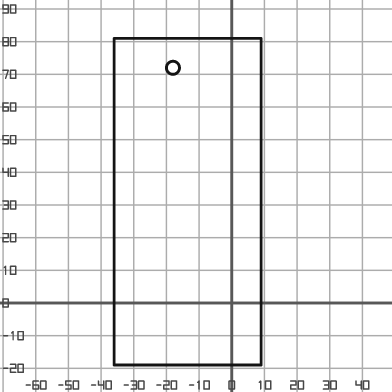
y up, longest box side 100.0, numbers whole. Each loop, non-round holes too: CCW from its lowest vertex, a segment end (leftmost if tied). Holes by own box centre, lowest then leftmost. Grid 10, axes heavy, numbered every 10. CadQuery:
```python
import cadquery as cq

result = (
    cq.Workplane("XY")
    .moveTo(-36.0, -19.0)
    .lineTo(9.0, -19.0)
    .lineTo(9.0, 81.0)
    .lineTo(-36.0, 81.0)
    .close()
    .moveTo(-18.0, 72.0)
    .circle(2.0)
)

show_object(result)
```